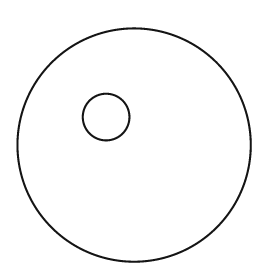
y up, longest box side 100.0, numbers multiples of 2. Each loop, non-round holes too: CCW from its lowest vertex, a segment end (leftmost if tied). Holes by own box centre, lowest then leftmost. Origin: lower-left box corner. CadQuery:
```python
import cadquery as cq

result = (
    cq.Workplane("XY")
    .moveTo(50.0, 50.0)
    .circle(50.0)
    .moveTo(38.0, 62.0)
    .circle(10.0)
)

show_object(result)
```